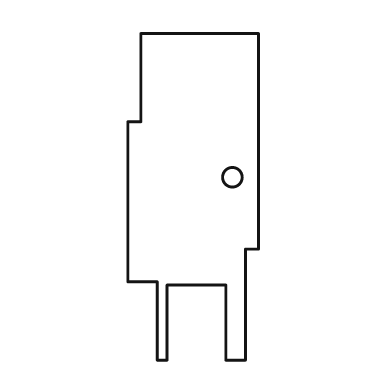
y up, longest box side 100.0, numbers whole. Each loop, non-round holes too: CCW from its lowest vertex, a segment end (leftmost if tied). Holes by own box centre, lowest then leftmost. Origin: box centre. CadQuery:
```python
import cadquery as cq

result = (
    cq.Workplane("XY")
    .moveTo(-11.0, -50.0)
    .lineTo(-8.0, -50.0)
    .lineTo(-8.0, -27.0)
    .lineTo(10.0, -27.0)
    .lineTo(10.0, -50.0)
    .lineTo(16.0, -50.0)
    .lineTo(16.0, -16.0)
    .lineTo(20.0, -16.0)
    .lineTo(20.0, 50.0)
    .lineTo(-16.0, 50.0)
    .lineTo(-16.0, 23.0)
    .lineTo(-20.0, 23.0)
    .lineTo(-20.0, -26.0)
    .lineTo(-11.0, -26.0)
    .close()
    .moveTo(12.0, 6.0)
    .circle(3.0)
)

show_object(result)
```